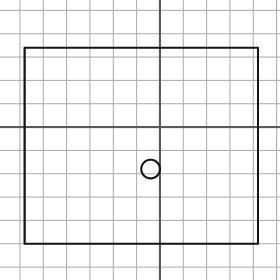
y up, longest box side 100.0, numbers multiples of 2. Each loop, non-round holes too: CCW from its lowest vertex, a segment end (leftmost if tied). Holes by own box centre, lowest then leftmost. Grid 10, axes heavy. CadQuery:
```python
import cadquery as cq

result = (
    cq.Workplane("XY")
    .moveTo(-58.0, -50.0)
    .lineTo(42.0, -50.0)
    .lineTo(42.0, 34.0)
    .lineTo(-58.0, 34.0)
    .close()
    .moveTo(-4.0, -18.0)
    .circle(4.0)
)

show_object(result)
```